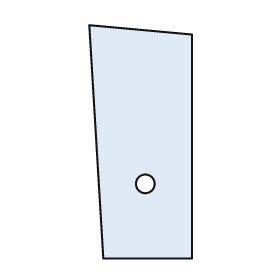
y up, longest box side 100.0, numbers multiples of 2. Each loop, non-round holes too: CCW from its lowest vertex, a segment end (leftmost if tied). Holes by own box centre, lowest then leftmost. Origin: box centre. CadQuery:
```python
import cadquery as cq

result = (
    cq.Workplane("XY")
    .moveTo(-16.0, -50.0)
    .lineTo(22.0, -50.0)
    .lineTo(22.0, 46.0)
    .lineTo(-22.0, 50.0)
    .close()
    .moveTo(2.0, -18.0)
    .circle(4.0)
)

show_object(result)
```